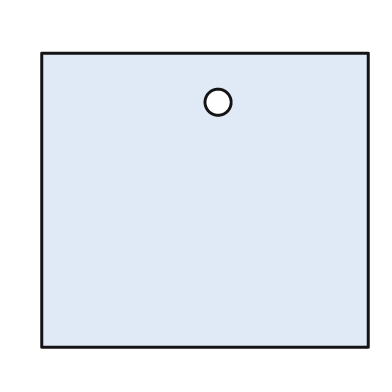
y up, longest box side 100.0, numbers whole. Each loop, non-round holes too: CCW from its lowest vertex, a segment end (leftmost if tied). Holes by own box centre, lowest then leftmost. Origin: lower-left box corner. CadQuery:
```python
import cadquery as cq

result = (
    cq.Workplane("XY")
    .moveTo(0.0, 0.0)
    .lineTo(100.0, 0.0)
    .lineTo(100.0, 90.0)
    .lineTo(0.0, 90.0)
    .close()
    .moveTo(54.0, 75.0)
    .circle(4.0)
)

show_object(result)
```